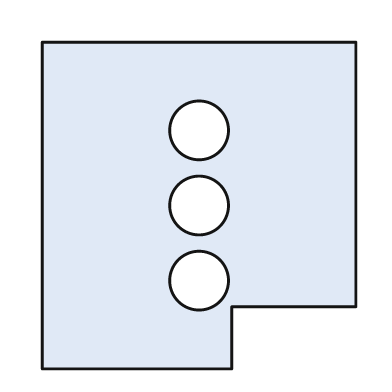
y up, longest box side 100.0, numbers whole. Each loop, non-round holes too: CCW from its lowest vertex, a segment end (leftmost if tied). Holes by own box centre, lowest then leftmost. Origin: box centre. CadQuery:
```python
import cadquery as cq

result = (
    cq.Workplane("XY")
    .moveTo(-48.0, -50.0)
    .lineTo(10.0, -50.0)
    .lineTo(10.0, -31.0)
    .lineTo(48.0, -31.0)
    .lineTo(48.0, 50.0)
    .lineTo(-48.0, 50.0)
    .close()
    .moveTo(0.0, -23.0)
    .circle(9.0)
    .moveTo(0.0, 0.0)
    .circle(9.0)
    .moveTo(0.0, 23.0)
    .circle(9.0)
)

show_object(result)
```